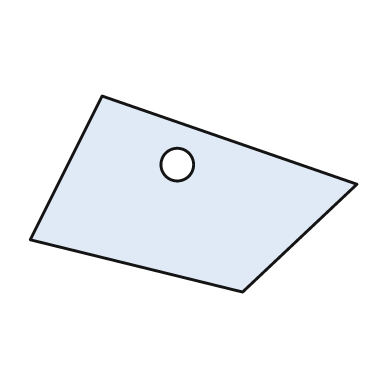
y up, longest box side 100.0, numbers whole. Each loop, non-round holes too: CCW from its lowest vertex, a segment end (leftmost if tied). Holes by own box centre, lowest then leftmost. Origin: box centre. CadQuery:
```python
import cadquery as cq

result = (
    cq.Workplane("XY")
    .moveTo(15.0, -30.0)
    .lineTo(50.0, 3.0)
    .lineTo(-28.0, 30.0)
    .lineTo(-50.0, -14.0)
    .close()
    .moveTo(-5.0, 9.0)
    .circle(5.0)
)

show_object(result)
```